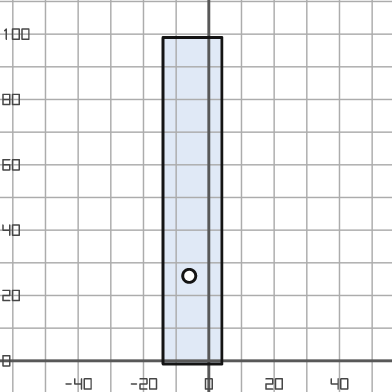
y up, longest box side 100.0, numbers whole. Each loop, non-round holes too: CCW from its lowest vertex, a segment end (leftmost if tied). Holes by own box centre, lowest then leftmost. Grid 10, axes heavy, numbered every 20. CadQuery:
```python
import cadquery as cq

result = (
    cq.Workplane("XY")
    .moveTo(-14.0, -1.0)
    .lineTo(4.0, -1.0)
    .lineTo(4.0, 99.0)
    .lineTo(-14.0, 99.0)
    .close()
    .moveTo(-6.0, 26.0)
    .circle(2.0)
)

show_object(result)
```